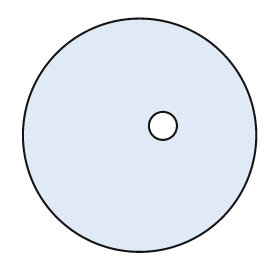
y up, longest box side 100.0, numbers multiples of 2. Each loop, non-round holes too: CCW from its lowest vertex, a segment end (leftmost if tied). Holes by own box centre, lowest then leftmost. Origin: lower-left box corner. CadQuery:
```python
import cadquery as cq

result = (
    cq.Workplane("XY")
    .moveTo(50.0, 50.0)
    .circle(50.0)
    .moveTo(60.0, 54.0)
    .circle(6.0)
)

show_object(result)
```